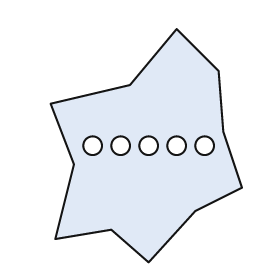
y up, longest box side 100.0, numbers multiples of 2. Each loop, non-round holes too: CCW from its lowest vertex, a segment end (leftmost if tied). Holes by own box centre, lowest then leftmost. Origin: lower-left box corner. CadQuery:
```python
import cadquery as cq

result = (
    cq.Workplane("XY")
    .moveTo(42.0, 0.0)
    .lineTo(62.0, 22.0)
    .lineTo(82.0, 32.0)
    .lineTo(74.0, 56.0)
    .lineTo(72.0, 82.0)
    .lineTo(54.0, 100.0)
    .lineTo(34.0, 76.0)
    .lineTo(0.0, 68.0)
    .lineTo(10.0, 42.0)
    .lineTo(2.0, 10.0)
    .lineTo(26.0, 14.0)
    .close()
    .moveTo(18.0, 50.0)
    .circle(4.0)
    .moveTo(30.0, 50.0)
    .circle(4.0)
    .moveTo(42.0, 50.0)
    .circle(4.0)
    .moveTo(54.0, 50.0)
    .circle(4.0)
    .moveTo(66.0, 50.0)
    .circle(4.0)
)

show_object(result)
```